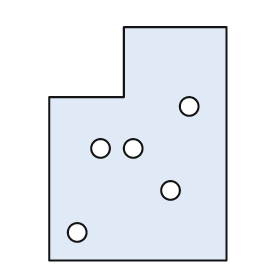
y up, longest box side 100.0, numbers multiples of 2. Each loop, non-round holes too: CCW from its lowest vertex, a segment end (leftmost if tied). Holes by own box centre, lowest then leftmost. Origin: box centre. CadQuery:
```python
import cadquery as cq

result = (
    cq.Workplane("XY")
    .moveTo(-38.0, -50.0)
    .lineTo(38.0, -50.0)
    .lineTo(38.0, 50.0)
    .lineTo(-6.0, 50.0)
    .lineTo(-6.0, 20.0)
    .lineTo(-38.0, 20.0)
    .close()
    .moveTo(-26.0, -38.0)
    .circle(4.0)
    .moveTo(14.0, -20.0)
    .circle(4.0)
    .moveTo(-16.0, -2.0)
    .circle(4.0)
    .moveTo(-2.0, -2.0)
    .circle(4.0)
    .moveTo(22.0, 16.0)
    .circle(4.0)
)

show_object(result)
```